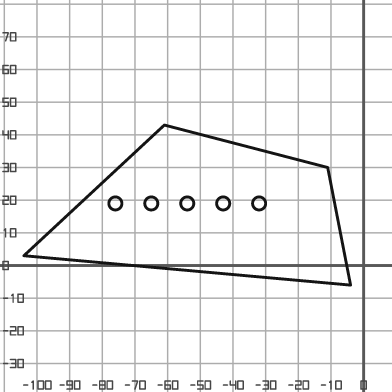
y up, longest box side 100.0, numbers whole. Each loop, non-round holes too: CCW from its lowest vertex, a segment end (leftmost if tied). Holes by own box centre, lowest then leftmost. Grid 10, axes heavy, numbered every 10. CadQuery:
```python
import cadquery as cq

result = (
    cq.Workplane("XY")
    .moveTo(-4.0, -6.0)
    .lineTo(-11.0, 30.0)
    .lineTo(-61.0, 43.0)
    .lineTo(-104.0, 3.0)
    .close()
    .moveTo(-76.0, 19.0)
    .circle(2.0)
    .moveTo(-65.0, 19.0)
    .circle(2.0)
    .moveTo(-54.0, 19.0)
    .circle(2.0)
    .moveTo(-43.0, 19.0)
    .circle(2.0)
    .moveTo(-32.0, 19.0)
    .circle(2.0)
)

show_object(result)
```